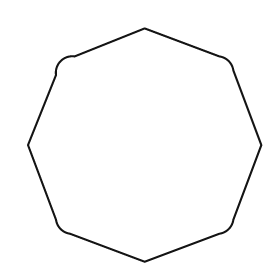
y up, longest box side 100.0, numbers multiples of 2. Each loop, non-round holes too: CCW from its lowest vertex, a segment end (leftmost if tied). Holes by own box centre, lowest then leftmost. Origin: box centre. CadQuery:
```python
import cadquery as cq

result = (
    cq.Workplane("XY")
    .moveTo(0.0, -50.0)
    .lineTo(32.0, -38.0)
    .threePointArc((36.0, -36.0), (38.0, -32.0))
    .lineTo(50.0, 0.0)
    .lineTo(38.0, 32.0)
    .threePointArc((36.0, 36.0), (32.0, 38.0))
    .lineTo(0.0, 50.0)
    .lineTo(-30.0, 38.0)
    .threePointArc((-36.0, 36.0), (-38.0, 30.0))
    .lineTo(-50.0, 0.0)
    .lineTo(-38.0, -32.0)
    .threePointArc((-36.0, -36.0), (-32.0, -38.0))
    .close()
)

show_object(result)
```